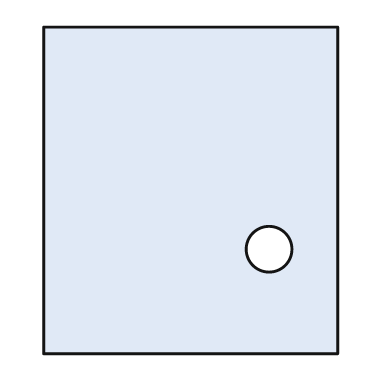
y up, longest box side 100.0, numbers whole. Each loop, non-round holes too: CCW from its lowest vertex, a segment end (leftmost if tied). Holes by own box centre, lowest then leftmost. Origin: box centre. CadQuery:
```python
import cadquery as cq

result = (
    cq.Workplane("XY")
    .moveTo(-45.0, -50.0)
    .lineTo(45.0, -50.0)
    .lineTo(45.0, 50.0)
    .lineTo(-45.0, 50.0)
    .close()
    .moveTo(24.0, -18.0)
    .circle(7.0)
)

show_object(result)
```